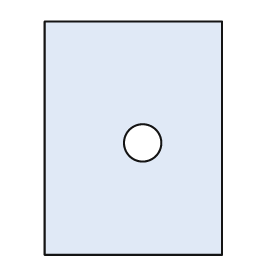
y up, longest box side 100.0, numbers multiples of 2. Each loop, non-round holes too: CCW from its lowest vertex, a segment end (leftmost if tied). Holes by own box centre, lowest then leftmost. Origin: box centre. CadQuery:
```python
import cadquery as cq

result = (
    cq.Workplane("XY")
    .moveTo(-38.0, -50.0)
    .lineTo(38.0, -50.0)
    .lineTo(38.0, 50.0)
    .lineTo(-38.0, 50.0)
    .close()
    .moveTo(4.0, -2.0)
    .circle(8.0)
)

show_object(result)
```